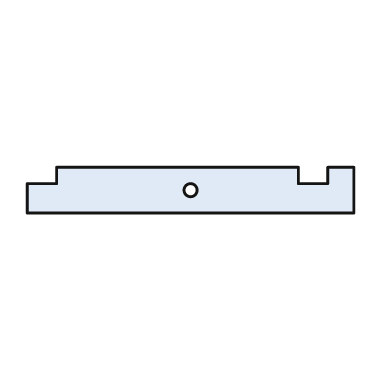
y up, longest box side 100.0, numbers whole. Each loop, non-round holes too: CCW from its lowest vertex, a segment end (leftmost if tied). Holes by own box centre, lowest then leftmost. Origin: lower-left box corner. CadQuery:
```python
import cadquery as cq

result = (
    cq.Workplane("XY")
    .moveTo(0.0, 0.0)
    .lineTo(100.0, 0.0)
    .lineTo(100.0, 14.0)
    .lineTo(92.0, 14.0)
    .lineTo(92.0, 9.0)
    .lineTo(83.0, 9.0)
    .lineTo(83.0, 14.0)
    .lineTo(9.0, 14.0)
    .lineTo(9.0, 9.0)
    .lineTo(0.0, 9.0)
    .close()
    .moveTo(50.0, 7.0)
    .circle(2.0)
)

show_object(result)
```